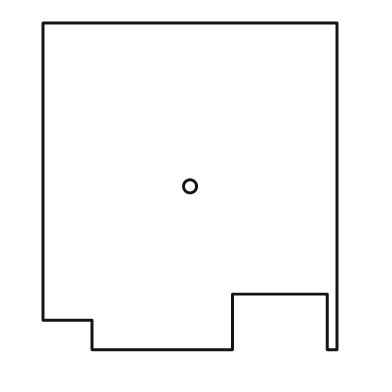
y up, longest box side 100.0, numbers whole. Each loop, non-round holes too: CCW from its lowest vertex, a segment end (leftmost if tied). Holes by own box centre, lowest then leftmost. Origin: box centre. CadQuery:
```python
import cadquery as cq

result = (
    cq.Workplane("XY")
    .moveTo(-30.0, -50.0)
    .lineTo(13.0, -50.0)
    .lineTo(13.0, -33.0)
    .lineTo(42.0, -33.0)
    .lineTo(42.0, -50.0)
    .lineTo(45.0, -50.0)
    .lineTo(45.0, 50.0)
    .lineTo(-45.0, 50.0)
    .lineTo(-45.0, -41.0)
    .lineTo(-30.0, -41.0)
    .close()
    .moveTo(0.0, 0.0)
    .circle(2.0)
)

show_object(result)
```